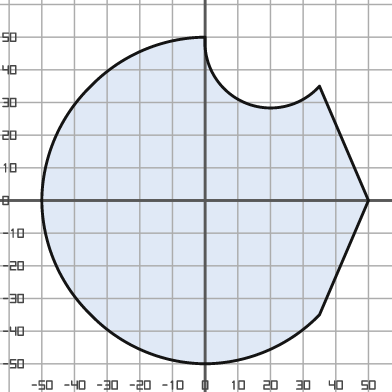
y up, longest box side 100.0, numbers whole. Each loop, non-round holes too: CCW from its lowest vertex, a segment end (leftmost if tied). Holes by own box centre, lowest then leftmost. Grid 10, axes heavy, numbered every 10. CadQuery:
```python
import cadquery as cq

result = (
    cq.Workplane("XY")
    .moveTo(0.0, -50.0)
    .threePointArc((19.0, -46.0), (35.0, -35.0))
    .lineTo(50.0, 0.0)
    .lineTo(35.0, 35.0)
    .threePointArc((12.0, 30.0), (0.0, 50.0))
    .threePointArc((-19.0, 46.0), (-35.0, 35.0))
    .threePointArc((-46.0, 19.0), (-50.0, 0.0))
    .threePointArc((-46.0, -19.0), (-35.0, -35.0))
    .threePointArc((-19.0, -46.0), (0.0, -50.0))
    .close()
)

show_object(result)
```